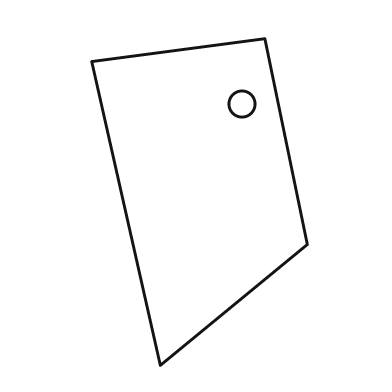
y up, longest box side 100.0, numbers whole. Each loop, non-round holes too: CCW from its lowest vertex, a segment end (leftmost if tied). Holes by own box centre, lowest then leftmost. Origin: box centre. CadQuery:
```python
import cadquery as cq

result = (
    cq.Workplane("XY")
    .moveTo(-12.0, -50.0)
    .lineTo(33.0, -13.0)
    .lineTo(20.0, 50.0)
    .lineTo(-33.0, 43.0)
    .close()
    .moveTo(13.0, 30.0)
    .circle(4.0)
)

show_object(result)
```